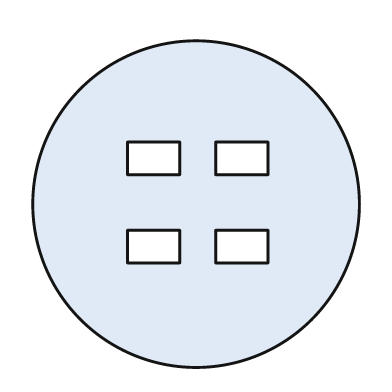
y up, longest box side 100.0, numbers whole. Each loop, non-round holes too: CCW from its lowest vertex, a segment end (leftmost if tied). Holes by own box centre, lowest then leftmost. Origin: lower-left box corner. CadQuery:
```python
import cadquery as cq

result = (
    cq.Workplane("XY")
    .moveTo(50.0, 50.0)
    .circle(50.0)
    .moveTo(29.0, 32.0)
    .lineTo(45.0, 32.0)
    .lineTo(45.0, 42.0)
    .lineTo(29.0, 42.0)
    .close()
    .moveTo(56.0, 32.0)
    .lineTo(72.0, 32.0)
    .lineTo(72.0, 42.0)
    .lineTo(56.0, 42.0)
    .close()
    .moveTo(29.0, 59.0)
    .lineTo(45.0, 59.0)
    .lineTo(45.0, 69.0)
    .lineTo(29.0, 69.0)
    .close()
    .moveTo(56.0, 59.0)
    .lineTo(72.0, 59.0)
    .lineTo(72.0, 69.0)
    .lineTo(56.0, 69.0)
    .close()
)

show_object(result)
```